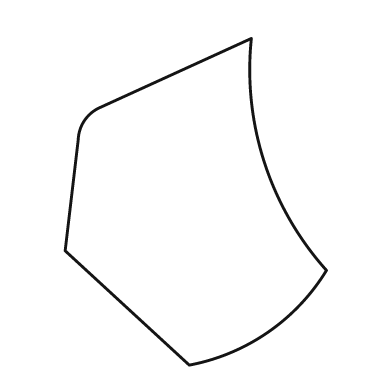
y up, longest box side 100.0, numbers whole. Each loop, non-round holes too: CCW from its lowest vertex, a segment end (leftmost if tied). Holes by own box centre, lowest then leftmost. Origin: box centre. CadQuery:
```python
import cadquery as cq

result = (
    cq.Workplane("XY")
    .moveTo(-2.0, -50.0)
    .threePointArc((22.0, -40.0), (40.0, -21.0))
    .threePointArc((21.0, 12.0), (17.0, 50.0))
    .lineTo(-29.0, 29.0)
    .threePointArc((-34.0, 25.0), (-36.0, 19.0))
    .lineTo(-40.0, -15.0)
    .close()
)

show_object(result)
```